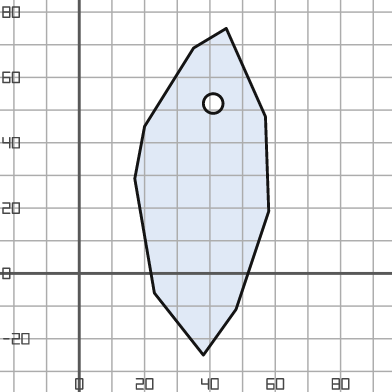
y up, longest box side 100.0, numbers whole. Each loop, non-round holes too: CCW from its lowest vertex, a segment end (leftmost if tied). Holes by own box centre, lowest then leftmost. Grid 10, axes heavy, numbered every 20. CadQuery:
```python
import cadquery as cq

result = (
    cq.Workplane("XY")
    .moveTo(38.0, -25.0)
    .lineTo(48.0, -11.0)
    .lineTo(58.0, 19.0)
    .lineTo(57.0, 48.0)
    .lineTo(45.0, 75.0)
    .lineTo(35.0, 69.0)
    .lineTo(20.0, 45.0)
    .lineTo(17.0, 29.0)
    .lineTo(23.0, -6.0)
    .close()
    .moveTo(41.0, 52.0)
    .circle(3.0)
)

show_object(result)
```